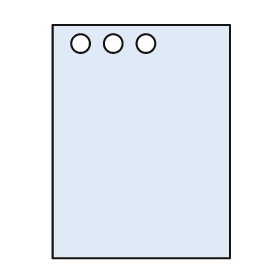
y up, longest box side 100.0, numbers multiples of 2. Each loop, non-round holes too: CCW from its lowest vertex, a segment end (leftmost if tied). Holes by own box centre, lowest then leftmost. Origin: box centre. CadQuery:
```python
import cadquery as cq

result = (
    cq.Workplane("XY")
    .moveTo(-38.0, -50.0)
    .lineTo(38.0, -50.0)
    .lineTo(38.0, 50.0)
    .lineTo(-38.0, 50.0)
    .close()
    .moveTo(-26.0, 42.0)
    .circle(4.0)
    .moveTo(-12.0, 42.0)
    .circle(4.0)
    .moveTo(2.0, 42.0)
    .circle(4.0)
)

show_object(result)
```